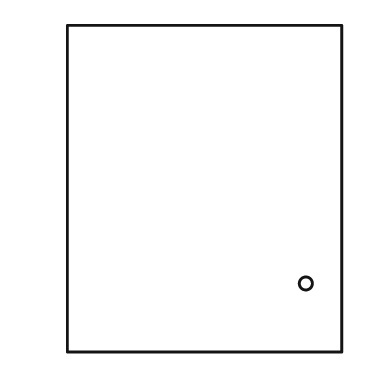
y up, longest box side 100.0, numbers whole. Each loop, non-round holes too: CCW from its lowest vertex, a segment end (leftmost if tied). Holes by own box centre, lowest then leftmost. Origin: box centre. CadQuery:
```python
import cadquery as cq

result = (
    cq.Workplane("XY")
    .moveTo(-42.0, -50.0)
    .lineTo(42.0, -50.0)
    .lineTo(42.0, 50.0)
    .lineTo(-42.0, 50.0)
    .close()
    .moveTo(31.0, -29.0)
    .circle(2.0)
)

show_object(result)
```